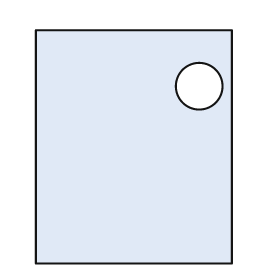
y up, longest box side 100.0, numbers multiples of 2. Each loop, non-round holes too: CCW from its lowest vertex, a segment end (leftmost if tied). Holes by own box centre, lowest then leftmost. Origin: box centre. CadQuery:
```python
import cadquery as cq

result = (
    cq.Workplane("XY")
    .moveTo(-42.0, -50.0)
    .lineTo(42.0, -50.0)
    .lineTo(42.0, 50.0)
    .lineTo(-42.0, 50.0)
    .close()
    .moveTo(28.0, 26.0)
    .circle(10.0)
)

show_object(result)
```